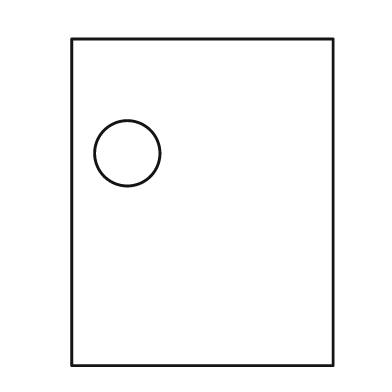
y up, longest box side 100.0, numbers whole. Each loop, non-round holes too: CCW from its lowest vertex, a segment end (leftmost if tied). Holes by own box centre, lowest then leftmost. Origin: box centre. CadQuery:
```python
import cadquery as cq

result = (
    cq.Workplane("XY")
    .moveTo(-40.0, -50.0)
    .lineTo(40.0, -50.0)
    .lineTo(40.0, 50.0)
    .lineTo(-40.0, 50.0)
    .close()
    .moveTo(-23.0, 15.0)
    .circle(10.0)
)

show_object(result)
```